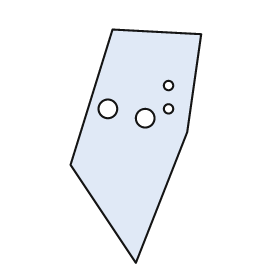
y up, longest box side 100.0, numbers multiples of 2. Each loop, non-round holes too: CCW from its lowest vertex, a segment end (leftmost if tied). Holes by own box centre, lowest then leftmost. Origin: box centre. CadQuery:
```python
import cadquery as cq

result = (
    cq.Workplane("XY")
    .moveTo(0.0, -50.0)
    .lineTo(22.0, 6.0)
    .lineTo(28.0, 48.0)
    .lineTo(-10.0, 50.0)
    .lineTo(-28.0, -8.0)
    .close()
    .moveTo(4.0, 12.0)
    .circle(4.0)
    .moveTo(-12.0, 16.0)
    .circle(4.0)
    .moveTo(14.0, 16.0)
    .circle(2.0)
    .moveTo(14.0, 26.0)
    .circle(2.0)
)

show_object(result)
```